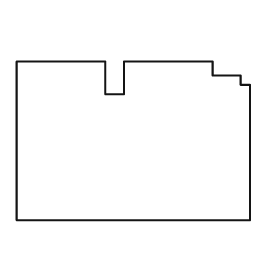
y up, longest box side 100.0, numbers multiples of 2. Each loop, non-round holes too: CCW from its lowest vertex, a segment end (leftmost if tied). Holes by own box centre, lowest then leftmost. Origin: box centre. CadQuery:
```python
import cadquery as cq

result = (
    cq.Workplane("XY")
    .moveTo(-50.0, -34.0)
    .lineTo(50.0, -34.0)
    .lineTo(50.0, 24.0)
    .lineTo(46.0, 24.0)
    .lineTo(46.0, 28.0)
    .lineTo(34.0, 28.0)
    .lineTo(34.0, 34.0)
    .lineTo(-4.0, 34.0)
    .lineTo(-4.0, 20.0)
    .lineTo(-12.0, 20.0)
    .lineTo(-12.0, 34.0)
    .lineTo(-50.0, 34.0)
    .close()
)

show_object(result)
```